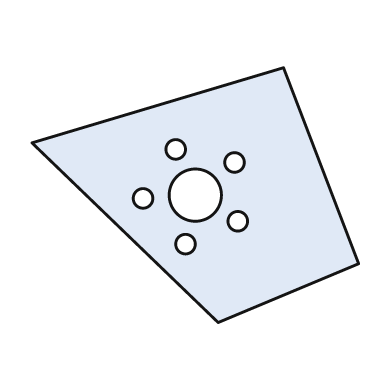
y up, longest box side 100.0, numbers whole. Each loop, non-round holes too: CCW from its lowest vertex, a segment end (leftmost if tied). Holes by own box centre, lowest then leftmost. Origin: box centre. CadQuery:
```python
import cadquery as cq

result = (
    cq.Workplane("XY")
    .moveTo(7.0, -39.0)
    .lineTo(50.0, -21.0)
    .lineTo(27.0, 39.0)
    .lineTo(-50.0, 16.0)
    .close()
    .moveTo(-3.0, -15.0)
    .circle(3.0)
    .moveTo(13.0, -8.0)
    .circle(3.0)
    .moveTo(-16.0, -1.0)
    .circle(3.0)
    .moveTo(0.0, 0.0)
    .circle(8.0)
    .moveTo(12.0, 10.0)
    .circle(3.0)
    .moveTo(-6.0, 14.0)
    .circle(3.0)
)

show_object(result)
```